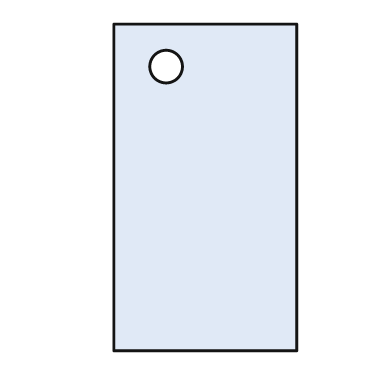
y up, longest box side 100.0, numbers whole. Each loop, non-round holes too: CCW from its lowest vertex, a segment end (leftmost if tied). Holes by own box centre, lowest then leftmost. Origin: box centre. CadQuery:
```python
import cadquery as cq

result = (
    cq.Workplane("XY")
    .moveTo(-28.0, -50.0)
    .lineTo(28.0, -50.0)
    .lineTo(28.0, 50.0)
    .lineTo(-28.0, 50.0)
    .close()
    .moveTo(-12.0, 37.0)
    .circle(5.0)
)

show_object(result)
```